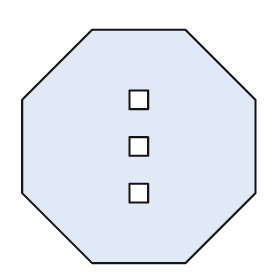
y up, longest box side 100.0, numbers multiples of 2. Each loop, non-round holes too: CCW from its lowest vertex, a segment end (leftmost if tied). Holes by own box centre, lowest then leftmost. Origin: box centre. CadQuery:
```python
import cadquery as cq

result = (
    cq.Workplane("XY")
    .moveTo(-20.0, -50.0)
    .lineTo(20.0, -50.0)
    .lineTo(50.0, -20.0)
    .lineTo(50.0, 20.0)
    .lineTo(20.0, 50.0)
    .lineTo(-20.0, 50.0)
    .lineTo(-50.0, 20.0)
    .lineTo(-50.0, -20.0)
    .close()
    .moveTo(-4.0, -24.0)
    .lineTo(4.0, -24.0)
    .lineTo(4.0, -16.0)
    .lineTo(-4.0, -16.0)
    .close()
    .moveTo(-4.0, -4.0)
    .lineTo(4.0, -4.0)
    .lineTo(4.0, 4.0)
    .lineTo(-4.0, 4.0)
    .close()
    .moveTo(-4.0, 16.0)
    .lineTo(4.0, 16.0)
    .lineTo(4.0, 24.0)
    .lineTo(-4.0, 24.0)
    .close()
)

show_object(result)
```